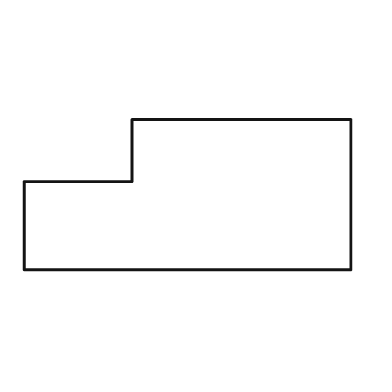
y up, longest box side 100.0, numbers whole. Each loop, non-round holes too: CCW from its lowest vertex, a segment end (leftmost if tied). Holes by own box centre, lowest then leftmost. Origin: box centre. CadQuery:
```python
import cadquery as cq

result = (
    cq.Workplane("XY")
    .moveTo(-50.0, -23.0)
    .lineTo(50.0, -23.0)
    .lineTo(50.0, 23.0)
    .lineTo(-17.0, 23.0)
    .lineTo(-17.0, 4.0)
    .lineTo(-50.0, 4.0)
    .close()
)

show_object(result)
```